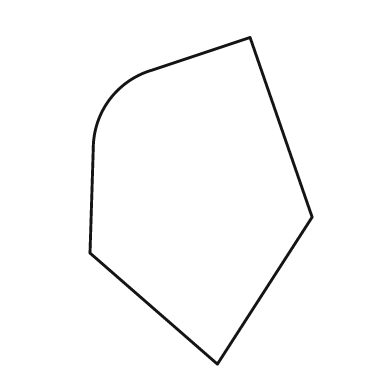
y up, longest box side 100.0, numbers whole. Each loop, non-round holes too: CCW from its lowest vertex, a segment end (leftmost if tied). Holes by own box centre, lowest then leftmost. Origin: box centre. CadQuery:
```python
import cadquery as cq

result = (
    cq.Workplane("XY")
    .moveTo(5.0, -50.0)
    .lineTo(34.0, -5.0)
    .lineTo(15.0, 50.0)
    .lineTo(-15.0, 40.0)
    .threePointArc((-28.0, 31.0), (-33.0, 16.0))
    .lineTo(-34.0, -16.0)
    .close()
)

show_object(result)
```